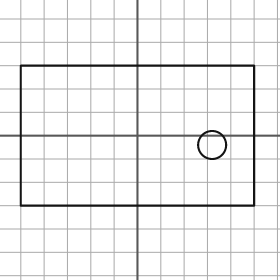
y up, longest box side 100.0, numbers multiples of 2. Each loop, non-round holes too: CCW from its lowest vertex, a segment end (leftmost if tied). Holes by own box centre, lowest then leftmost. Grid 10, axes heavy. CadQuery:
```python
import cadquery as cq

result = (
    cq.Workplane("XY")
    .moveTo(-50.0, -30.0)
    .lineTo(50.0, -30.0)
    .lineTo(50.0, 30.0)
    .lineTo(-50.0, 30.0)
    .close()
    .moveTo(32.0, -4.0)
    .circle(6.0)
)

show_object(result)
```